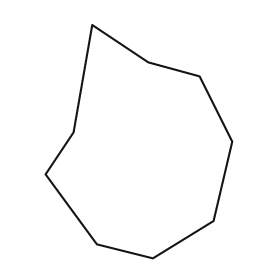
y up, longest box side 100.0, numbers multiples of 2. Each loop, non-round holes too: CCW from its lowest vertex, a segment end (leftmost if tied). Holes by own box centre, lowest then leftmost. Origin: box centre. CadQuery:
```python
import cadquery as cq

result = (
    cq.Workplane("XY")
    .moveTo(6.0, -50.0)
    .lineTo(32.0, -34.0)
    .lineTo(40.0, 0.0)
    .lineTo(26.0, 28.0)
    .lineTo(4.0, 34.0)
    .lineTo(-20.0, 50.0)
    .lineTo(-28.0, 4.0)
    .lineTo(-40.0, -14.0)
    .lineTo(-18.0, -44.0)
    .close()
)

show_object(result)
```